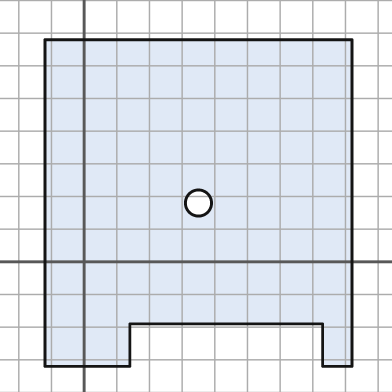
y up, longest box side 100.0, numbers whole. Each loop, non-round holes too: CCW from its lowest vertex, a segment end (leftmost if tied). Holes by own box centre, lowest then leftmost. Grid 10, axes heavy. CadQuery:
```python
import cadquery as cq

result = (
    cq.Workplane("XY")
    .moveTo(-12.0, -32.0)
    .lineTo(14.0, -32.0)
    .lineTo(14.0, -19.0)
    .lineTo(73.0, -19.0)
    .lineTo(73.0, -32.0)
    .lineTo(82.0, -32.0)
    .lineTo(82.0, 68.0)
    .lineTo(-12.0, 68.0)
    .close()
    .moveTo(35.0, 18.0)
    .circle(4.0)
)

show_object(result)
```